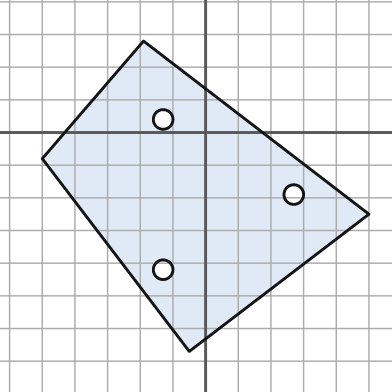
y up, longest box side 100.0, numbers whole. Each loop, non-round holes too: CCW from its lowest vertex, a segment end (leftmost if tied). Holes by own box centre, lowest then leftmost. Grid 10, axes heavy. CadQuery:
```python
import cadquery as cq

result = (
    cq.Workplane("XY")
    .moveTo(-5.0, -67.0)
    .lineTo(50.0, -25.0)
    .lineTo(-19.0, 28.0)
    .lineTo(-50.0, -8.0)
    .close()
    .moveTo(-13.0, -42.0)
    .circle(3.0)
    .moveTo(27.0, -19.0)
    .circle(3.0)
    .moveTo(-13.0, 4.0)
    .circle(3.0)
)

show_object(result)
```